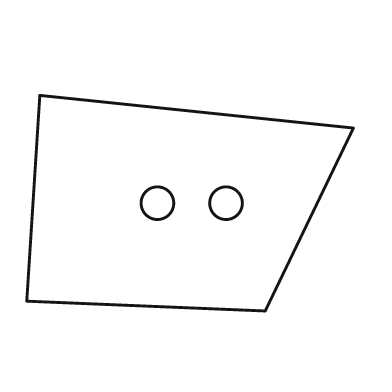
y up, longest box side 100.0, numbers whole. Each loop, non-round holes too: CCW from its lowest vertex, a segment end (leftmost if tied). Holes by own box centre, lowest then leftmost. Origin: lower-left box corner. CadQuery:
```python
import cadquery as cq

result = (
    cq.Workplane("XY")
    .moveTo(73.0, 0.0)
    .lineTo(100.0, 56.0)
    .lineTo(4.0, 66.0)
    .lineTo(0.0, 3.0)
    .close()
    .moveTo(40.0, 33.0)
    .circle(5.0)
    .moveTo(61.0, 33.0)
    .circle(5.0)
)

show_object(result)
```